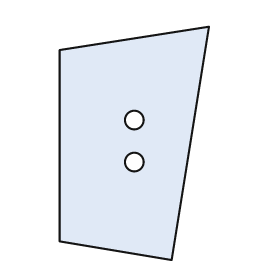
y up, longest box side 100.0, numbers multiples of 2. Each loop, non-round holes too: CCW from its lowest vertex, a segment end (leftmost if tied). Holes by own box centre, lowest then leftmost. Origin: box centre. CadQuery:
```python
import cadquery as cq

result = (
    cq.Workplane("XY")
    .moveTo(16.0, -50.0)
    .lineTo(32.0, 50.0)
    .lineTo(-32.0, 40.0)
    .lineTo(-32.0, -42.0)
    .close()
    .moveTo(0.0, -8.0)
    .circle(4.0)
    .moveTo(0.0, 10.0)
    .circle(4.0)
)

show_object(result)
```